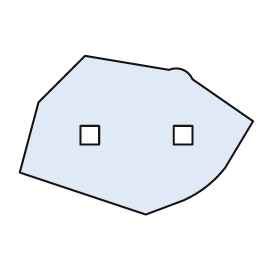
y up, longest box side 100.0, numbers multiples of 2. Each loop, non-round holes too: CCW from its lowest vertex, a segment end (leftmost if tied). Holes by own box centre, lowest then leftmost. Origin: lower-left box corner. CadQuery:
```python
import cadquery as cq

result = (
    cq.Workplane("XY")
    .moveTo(54.0, 0.0)
    .lineTo(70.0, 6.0)
    .threePointArc((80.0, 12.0), (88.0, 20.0))
    .lineTo(100.0, 40.0)
    .lineTo(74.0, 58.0)
    .threePointArc((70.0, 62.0), (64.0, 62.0))
    .lineTo(28.0, 68.0)
    .lineTo(8.0, 48.0)
    .lineTo(0.0, 18.0)
    .close()
    .moveTo(26.0, 30.0)
    .lineTo(34.0, 30.0)
    .lineTo(34.0, 38.0)
    .lineTo(26.0, 38.0)
    .close()
    .moveTo(66.0, 30.0)
    .lineTo(74.0, 30.0)
    .lineTo(74.0, 38.0)
    .lineTo(66.0, 38.0)
    .close()
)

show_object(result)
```